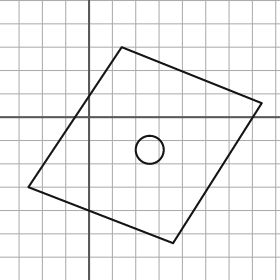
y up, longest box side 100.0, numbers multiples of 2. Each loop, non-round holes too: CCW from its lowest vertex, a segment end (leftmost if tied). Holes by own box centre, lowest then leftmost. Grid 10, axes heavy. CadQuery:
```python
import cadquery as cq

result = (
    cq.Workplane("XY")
    .moveTo(36.0, -54.0)
    .lineTo(74.0, 6.0)
    .lineTo(14.0, 30.0)
    .lineTo(-26.0, -30.0)
    .close()
    .moveTo(26.0, -14.0)
    .circle(6.0)
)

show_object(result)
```